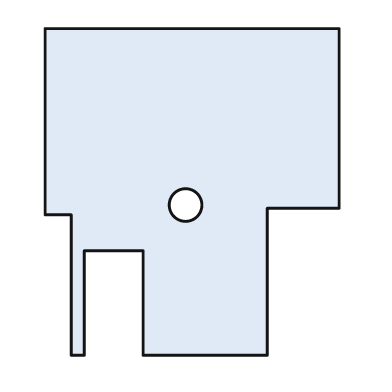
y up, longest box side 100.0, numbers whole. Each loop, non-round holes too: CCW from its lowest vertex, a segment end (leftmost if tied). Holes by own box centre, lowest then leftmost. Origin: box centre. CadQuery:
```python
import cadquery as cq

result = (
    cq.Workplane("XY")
    .moveTo(-37.0, -50.0)
    .lineTo(-33.0, -50.0)
    .lineTo(-33.0, -18.0)
    .lineTo(-15.0, -18.0)
    .lineTo(-15.0, -50.0)
    .lineTo(23.0, -50.0)
    .lineTo(23.0, -5.0)
    .lineTo(45.0, -5.0)
    .lineTo(45.0, 50.0)
    .lineTo(-45.0, 50.0)
    .lineTo(-45.0, -7.0)
    .lineTo(-37.0, -7.0)
    .close()
    .moveTo(-2.0, -4.0)
    .circle(5.0)
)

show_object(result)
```